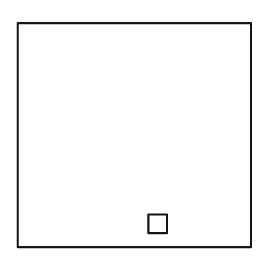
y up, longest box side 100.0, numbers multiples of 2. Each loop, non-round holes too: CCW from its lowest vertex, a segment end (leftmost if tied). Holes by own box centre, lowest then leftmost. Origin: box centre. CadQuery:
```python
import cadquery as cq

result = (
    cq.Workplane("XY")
    .moveTo(-50.0, -48.0)
    .lineTo(50.0, -48.0)
    .lineTo(50.0, 48.0)
    .lineTo(-50.0, 48.0)
    .close()
    .moveTo(6.0, -42.0)
    .lineTo(14.0, -42.0)
    .lineTo(14.0, -34.0)
    .lineTo(6.0, -34.0)
    .close()
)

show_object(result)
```